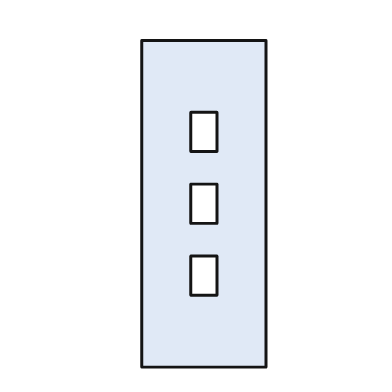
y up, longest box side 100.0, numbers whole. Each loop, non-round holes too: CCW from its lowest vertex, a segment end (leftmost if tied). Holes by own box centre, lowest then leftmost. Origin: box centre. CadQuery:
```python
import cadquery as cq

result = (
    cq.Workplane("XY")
    .moveTo(-19.0, -50.0)
    .lineTo(19.0, -50.0)
    .lineTo(19.0, 50.0)
    .lineTo(-19.0, 50.0)
    .close()
    .moveTo(-4.0, -28.0)
    .lineTo(4.0, -28.0)
    .lineTo(4.0, -16.0)
    .lineTo(-4.0, -16.0)
    .close()
    .moveTo(-4.0, -6.0)
    .lineTo(4.0, -6.0)
    .lineTo(4.0, 6.0)
    .lineTo(-4.0, 6.0)
    .close()
    .moveTo(-4.0, 16.0)
    .lineTo(4.0, 16.0)
    .lineTo(4.0, 28.0)
    .lineTo(-4.0, 28.0)
    .close()
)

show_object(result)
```